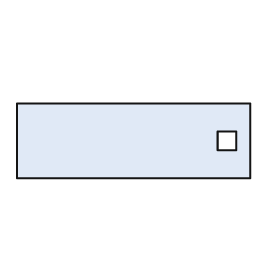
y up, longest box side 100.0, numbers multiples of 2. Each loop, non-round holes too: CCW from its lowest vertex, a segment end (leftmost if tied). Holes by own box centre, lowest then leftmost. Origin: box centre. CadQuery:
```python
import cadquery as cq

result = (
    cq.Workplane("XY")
    .moveTo(-50.0, -16.0)
    .lineTo(50.0, -16.0)
    .lineTo(50.0, 16.0)
    .lineTo(-50.0, 16.0)
    .close()
    .moveTo(36.0, -4.0)
    .lineTo(44.0, -4.0)
    .lineTo(44.0, 4.0)
    .lineTo(36.0, 4.0)
    .close()
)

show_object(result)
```